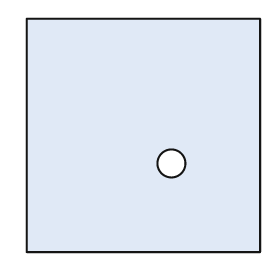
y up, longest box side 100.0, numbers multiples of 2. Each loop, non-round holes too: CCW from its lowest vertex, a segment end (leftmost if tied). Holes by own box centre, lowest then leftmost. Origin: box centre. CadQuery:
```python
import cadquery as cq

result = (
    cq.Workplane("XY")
    .moveTo(-50.0, -50.0)
    .lineTo(50.0, -50.0)
    .lineTo(50.0, 50.0)
    .lineTo(-50.0, 50.0)
    .close()
    .moveTo(12.0, -12.0)
    .circle(6.0)
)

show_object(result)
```